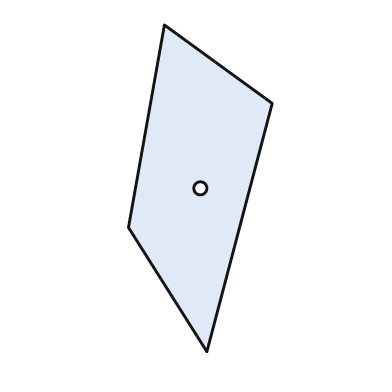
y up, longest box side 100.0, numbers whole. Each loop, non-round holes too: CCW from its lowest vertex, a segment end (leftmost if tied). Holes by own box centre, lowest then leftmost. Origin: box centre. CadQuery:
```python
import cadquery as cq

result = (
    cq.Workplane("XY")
    .moveTo(2.0, -50.0)
    .lineTo(22.0, 26.0)
    .lineTo(-11.0, 50.0)
    .lineTo(-22.0, -12.0)
    .close()
    .moveTo(0.0, 0.0)
    .circle(2.0)
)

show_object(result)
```